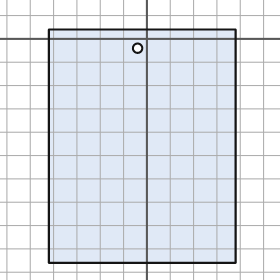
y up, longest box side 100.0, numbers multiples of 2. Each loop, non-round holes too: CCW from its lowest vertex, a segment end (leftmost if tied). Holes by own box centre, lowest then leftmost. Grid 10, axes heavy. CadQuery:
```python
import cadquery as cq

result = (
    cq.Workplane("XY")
    .moveTo(-42.0, -96.0)
    .lineTo(38.0, -96.0)
    .lineTo(38.0, 4.0)
    .lineTo(-42.0, 4.0)
    .close()
    .moveTo(-4.0, -4.0)
    .circle(2.0)
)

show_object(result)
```